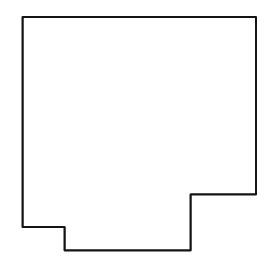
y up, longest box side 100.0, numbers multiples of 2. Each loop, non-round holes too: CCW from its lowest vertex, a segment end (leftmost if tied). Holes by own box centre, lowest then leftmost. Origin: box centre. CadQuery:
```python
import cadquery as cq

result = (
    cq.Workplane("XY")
    .moveTo(-32.0, -50.0)
    .lineTo(22.0, -50.0)
    .lineTo(22.0, -26.0)
    .lineTo(50.0, -26.0)
    .lineTo(50.0, 50.0)
    .lineTo(-50.0, 50.0)
    .lineTo(-50.0, -40.0)
    .lineTo(-32.0, -40.0)
    .close()
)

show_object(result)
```